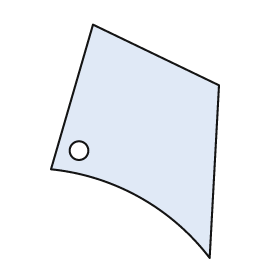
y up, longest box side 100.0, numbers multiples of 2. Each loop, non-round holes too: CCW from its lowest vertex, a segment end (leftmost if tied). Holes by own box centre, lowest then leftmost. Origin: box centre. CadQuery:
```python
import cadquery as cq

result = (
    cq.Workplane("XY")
    .moveTo(32.0, -50.0)
    .lineTo(36.0, 24.0)
    .lineTo(-18.0, 50.0)
    .lineTo(-36.0, -12.0)
    .threePointArc((2.0, -24.0), (32.0, -50.0))
    .close()
    .moveTo(-24.0, -4.0)
    .circle(4.0)
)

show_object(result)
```